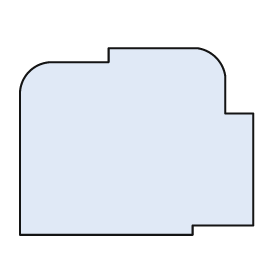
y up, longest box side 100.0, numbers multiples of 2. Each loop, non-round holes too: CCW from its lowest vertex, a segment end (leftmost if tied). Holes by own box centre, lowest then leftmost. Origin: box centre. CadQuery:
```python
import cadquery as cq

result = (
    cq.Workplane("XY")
    .moveTo(-50.0, -40.0)
    .lineTo(24.0, -40.0)
    .lineTo(24.0, -36.0)
    .lineTo(50.0, -36.0)
    .lineTo(50.0, 12.0)
    .lineTo(38.0, 12.0)
    .lineTo(38.0, 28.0)
    .threePointArc((34.0, 36.0), (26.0, 40.0))
    .lineTo(-12.0, 40.0)
    .lineTo(-12.0, 34.0)
    .lineTo(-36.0, 34.0)
    .threePointArc((-46.0, 30.0), (-50.0, 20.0))
    .close()
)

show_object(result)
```